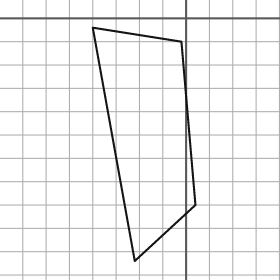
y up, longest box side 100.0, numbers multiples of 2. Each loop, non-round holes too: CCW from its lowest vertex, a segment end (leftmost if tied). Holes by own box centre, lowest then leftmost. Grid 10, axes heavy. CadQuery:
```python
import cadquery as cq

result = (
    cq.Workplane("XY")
    .moveTo(-22.0, -104.0)
    .lineTo(4.0, -80.0)
    .lineTo(-2.0, -10.0)
    .lineTo(-40.0, -4.0)
    .close()
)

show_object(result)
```